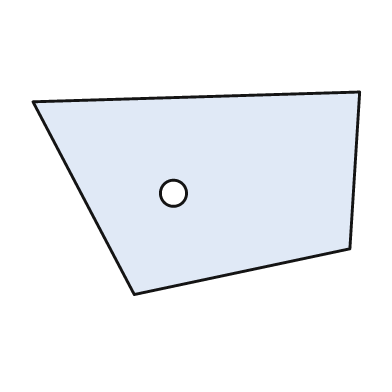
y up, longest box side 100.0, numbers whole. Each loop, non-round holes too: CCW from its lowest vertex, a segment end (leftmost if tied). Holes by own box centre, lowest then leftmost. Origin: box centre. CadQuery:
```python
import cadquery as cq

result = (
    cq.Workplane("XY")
    .moveTo(-19.0, -31.0)
    .lineTo(47.0, -17.0)
    .lineTo(50.0, 31.0)
    .lineTo(-50.0, 28.0)
    .close()
    .moveTo(-7.0, 0.0)
    .circle(4.0)
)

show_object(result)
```